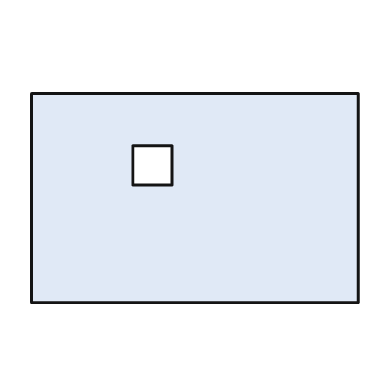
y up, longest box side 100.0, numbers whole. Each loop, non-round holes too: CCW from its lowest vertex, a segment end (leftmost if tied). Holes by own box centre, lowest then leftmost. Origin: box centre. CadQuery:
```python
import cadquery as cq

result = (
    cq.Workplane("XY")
    .moveTo(-50.0, -32.0)
    .lineTo(50.0, -32.0)
    .lineTo(50.0, 32.0)
    .lineTo(-50.0, 32.0)
    .close()
    .moveTo(-19.0, 4.0)
    .lineTo(-7.0, 4.0)
    .lineTo(-7.0, 16.0)
    .lineTo(-19.0, 16.0)
    .close()
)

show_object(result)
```